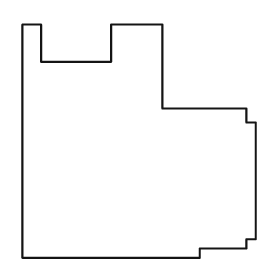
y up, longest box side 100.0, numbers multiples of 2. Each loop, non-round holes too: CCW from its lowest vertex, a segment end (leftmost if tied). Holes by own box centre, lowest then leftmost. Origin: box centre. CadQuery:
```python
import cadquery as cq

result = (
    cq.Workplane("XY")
    .moveTo(-50.0, -50.0)
    .lineTo(26.0, -50.0)
    .lineTo(26.0, -46.0)
    .lineTo(46.0, -46.0)
    .lineTo(46.0, -42.0)
    .lineTo(50.0, -42.0)
    .lineTo(50.0, 8.0)
    .lineTo(46.0, 8.0)
    .lineTo(46.0, 14.0)
    .lineTo(10.0, 14.0)
    .lineTo(10.0, 50.0)
    .lineTo(-12.0, 50.0)
    .lineTo(-12.0, 34.0)
    .lineTo(-42.0, 34.0)
    .lineTo(-42.0, 50.0)
    .lineTo(-50.0, 50.0)
    .close()
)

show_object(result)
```